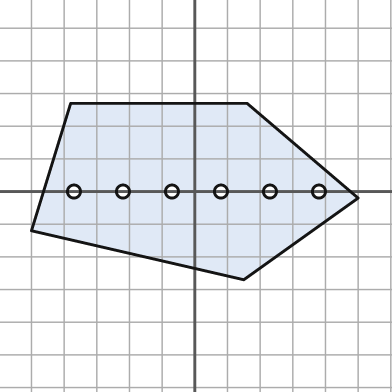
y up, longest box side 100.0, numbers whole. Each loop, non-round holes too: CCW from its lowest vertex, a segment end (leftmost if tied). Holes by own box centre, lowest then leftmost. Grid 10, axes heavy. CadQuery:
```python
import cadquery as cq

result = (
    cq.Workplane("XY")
    .moveTo(15.0, -27.0)
    .lineTo(50.0, -2.0)
    .lineTo(16.0, 27.0)
    .lineTo(-38.0, 27.0)
    .lineTo(-50.0, -12.0)
    .close()
    .moveTo(-37.0, 0.0)
    .circle(2.0)
    .moveTo(-22.0, 0.0)
    .circle(2.0)
    .moveTo(-7.0, 0.0)
    .circle(2.0)
    .moveTo(8.0, 0.0)
    .circle(2.0)
    .moveTo(23.0, 0.0)
    .circle(2.0)
    .moveTo(38.0, 0.0)
    .circle(2.0)
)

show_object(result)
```